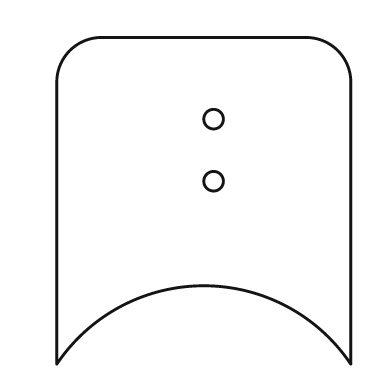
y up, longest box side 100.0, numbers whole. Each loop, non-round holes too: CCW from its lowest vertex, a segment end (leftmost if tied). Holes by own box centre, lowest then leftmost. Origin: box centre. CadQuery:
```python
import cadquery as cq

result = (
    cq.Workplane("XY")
    .moveTo(-45.0, -50.0)
    .threePointArc((0.0, -26.0), (45.0, -50.0))
    .lineTo(45.0, 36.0)
    .threePointArc((41.0, 46.0), (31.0, 50.0))
    .lineTo(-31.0, 50.0)
    .threePointArc((-41.0, 46.0), (-45.0, 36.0))
    .close()
    .moveTo(3.0, 6.0)
    .circle(3.0)
    .moveTo(3.0, 25.0)
    .circle(3.0)
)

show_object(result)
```